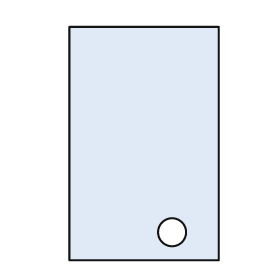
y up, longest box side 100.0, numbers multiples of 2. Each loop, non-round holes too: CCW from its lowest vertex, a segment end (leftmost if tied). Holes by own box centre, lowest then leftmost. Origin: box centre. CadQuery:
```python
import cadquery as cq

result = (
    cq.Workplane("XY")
    .moveTo(-32.0, -50.0)
    .lineTo(32.0, -50.0)
    .lineTo(32.0, 50.0)
    .lineTo(-32.0, 50.0)
    .close()
    .moveTo(12.0, -38.0)
    .circle(6.0)
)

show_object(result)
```